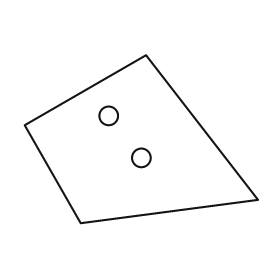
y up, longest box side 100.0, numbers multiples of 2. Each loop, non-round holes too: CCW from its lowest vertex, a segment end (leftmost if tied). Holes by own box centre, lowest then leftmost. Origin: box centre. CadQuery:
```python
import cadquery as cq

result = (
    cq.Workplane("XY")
    .moveTo(-26.0, -36.0)
    .lineTo(50.0, -26.0)
    .lineTo(2.0, 36.0)
    .lineTo(-50.0, 6.0)
    .close()
    .moveTo(0.0, -8.0)
    .circle(4.0)
    .moveTo(-14.0, 10.0)
    .circle(4.0)
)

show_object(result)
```